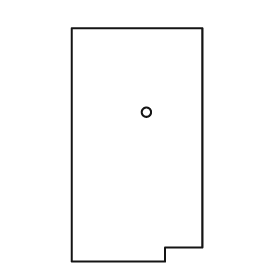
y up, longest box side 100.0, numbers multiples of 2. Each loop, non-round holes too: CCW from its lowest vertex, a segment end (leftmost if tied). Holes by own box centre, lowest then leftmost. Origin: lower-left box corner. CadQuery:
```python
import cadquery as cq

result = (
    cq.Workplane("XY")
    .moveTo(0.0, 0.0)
    .lineTo(40.0, 0.0)
    .lineTo(40.0, 6.0)
    .lineTo(56.0, 6.0)
    .lineTo(56.0, 100.0)
    .lineTo(0.0, 100.0)
    .close()
    .moveTo(32.0, 64.0)
    .circle(2.0)
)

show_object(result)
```